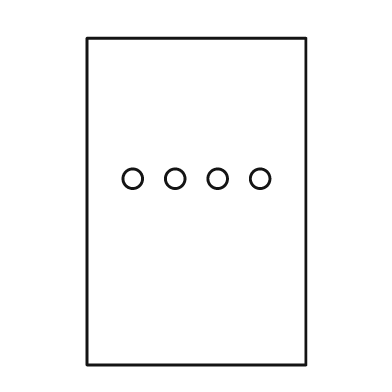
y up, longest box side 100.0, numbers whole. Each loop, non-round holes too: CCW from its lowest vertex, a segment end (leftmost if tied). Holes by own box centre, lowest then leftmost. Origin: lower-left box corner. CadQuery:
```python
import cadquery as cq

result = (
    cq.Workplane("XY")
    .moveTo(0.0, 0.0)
    .lineTo(67.0, 0.0)
    .lineTo(67.0, 100.0)
    .lineTo(0.0, 100.0)
    .close()
    .moveTo(14.0, 57.0)
    .circle(3.0)
    .moveTo(27.0, 57.0)
    .circle(3.0)
    .moveTo(40.0, 57.0)
    .circle(3.0)
    .moveTo(53.0, 57.0)
    .circle(3.0)
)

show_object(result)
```